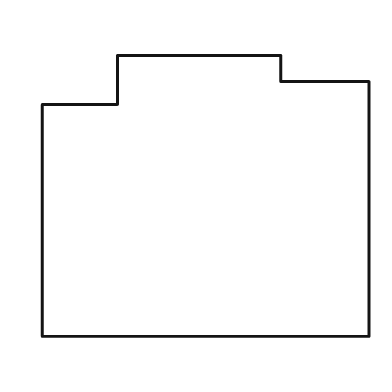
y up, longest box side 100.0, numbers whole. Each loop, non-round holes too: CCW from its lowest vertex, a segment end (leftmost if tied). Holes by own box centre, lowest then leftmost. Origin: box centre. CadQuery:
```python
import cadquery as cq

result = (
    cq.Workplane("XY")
    .moveTo(-50.0, -43.0)
    .lineTo(50.0, -43.0)
    .lineTo(50.0, 35.0)
    .lineTo(23.0, 35.0)
    .lineTo(23.0, 43.0)
    .lineTo(-27.0, 43.0)
    .lineTo(-27.0, 28.0)
    .lineTo(-50.0, 28.0)
    .close()
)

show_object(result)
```